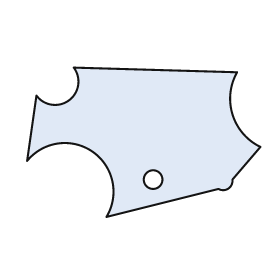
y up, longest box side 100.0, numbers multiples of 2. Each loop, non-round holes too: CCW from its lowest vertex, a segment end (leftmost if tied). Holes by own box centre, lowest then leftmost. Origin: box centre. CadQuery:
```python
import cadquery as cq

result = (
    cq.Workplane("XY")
    .moveTo(-16.0, -32.0)
    .lineTo(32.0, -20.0)
    .threePointArc((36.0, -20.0), (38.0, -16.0))
    .lineTo(50.0, -2.0)
    .threePointArc((38.0, 12.0), (40.0, 30.0))
    .lineTo(-30.0, 32.0)
    .threePointArc((-32.0, 18.0), (-46.0, 20.0))
    .lineTo(-50.0, -8.0)
    .threePointArc((-22.0, -4.0), (-16.0, -32.0))
    .close()
    .moveTo(4.0, -16.0)
    .circle(4.0)
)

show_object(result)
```